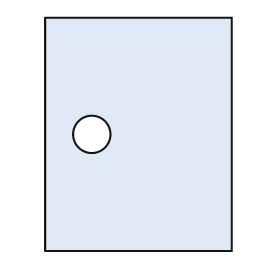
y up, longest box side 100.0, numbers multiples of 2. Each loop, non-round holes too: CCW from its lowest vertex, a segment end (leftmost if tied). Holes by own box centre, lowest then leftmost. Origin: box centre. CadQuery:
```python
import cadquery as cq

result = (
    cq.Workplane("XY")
    .moveTo(-40.0, -50.0)
    .lineTo(40.0, -50.0)
    .lineTo(40.0, 50.0)
    .lineTo(-40.0, 50.0)
    .close()
    .moveTo(-20.0, 0.0)
    .circle(8.0)
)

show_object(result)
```